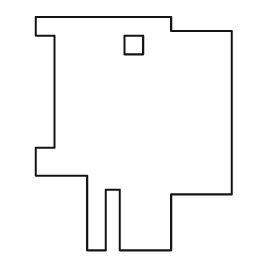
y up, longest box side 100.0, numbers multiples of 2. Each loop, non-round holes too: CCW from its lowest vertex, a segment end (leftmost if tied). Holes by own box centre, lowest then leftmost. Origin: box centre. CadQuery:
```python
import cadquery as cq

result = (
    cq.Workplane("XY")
    .moveTo(-20.0, -50.0)
    .lineTo(-12.0, -50.0)
    .lineTo(-12.0, -24.0)
    .lineTo(-6.0, -24.0)
    .lineTo(-6.0, -50.0)
    .lineTo(16.0, -50.0)
    .lineTo(16.0, -26.0)
    .lineTo(42.0, -26.0)
    .lineTo(42.0, 44.0)
    .lineTo(16.0, 44.0)
    .lineTo(16.0, 50.0)
    .lineTo(-42.0, 50.0)
    .lineTo(-42.0, 42.0)
    .lineTo(-34.0, 42.0)
    .lineTo(-34.0, -6.0)
    .lineTo(-42.0, -6.0)
    .lineTo(-42.0, -18.0)
    .lineTo(-20.0, -18.0)
    .close()
    .moveTo(-4.0, 34.0)
    .lineTo(4.0, 34.0)
    .lineTo(4.0, 42.0)
    .lineTo(-4.0, 42.0)
    .close()
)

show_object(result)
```